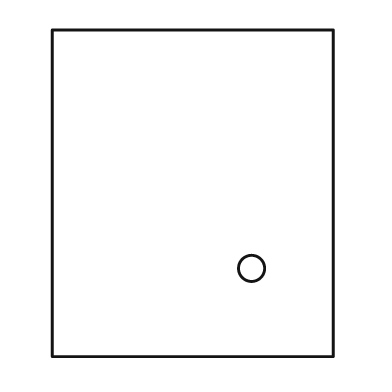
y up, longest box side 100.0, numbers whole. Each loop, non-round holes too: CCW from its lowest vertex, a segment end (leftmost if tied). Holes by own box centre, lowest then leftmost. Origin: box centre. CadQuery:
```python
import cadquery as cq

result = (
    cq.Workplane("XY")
    .moveTo(-43.0, -50.0)
    .lineTo(43.0, -50.0)
    .lineTo(43.0, 50.0)
    .lineTo(-43.0, 50.0)
    .close()
    .moveTo(18.0, -23.0)
    .circle(4.0)
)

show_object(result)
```